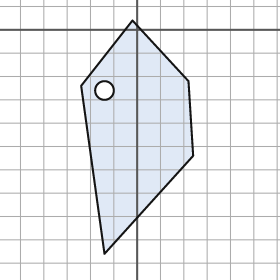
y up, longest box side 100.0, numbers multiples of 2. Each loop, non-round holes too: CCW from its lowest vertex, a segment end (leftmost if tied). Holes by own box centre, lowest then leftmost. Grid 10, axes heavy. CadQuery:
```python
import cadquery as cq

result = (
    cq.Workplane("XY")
    .moveTo(-14.0, -96.0)
    .lineTo(24.0, -54.0)
    .lineTo(22.0, -22.0)
    .lineTo(-2.0, 4.0)
    .lineTo(-24.0, -24.0)
    .close()
    .moveTo(-14.0, -26.0)
    .circle(4.0)
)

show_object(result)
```